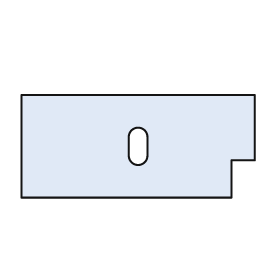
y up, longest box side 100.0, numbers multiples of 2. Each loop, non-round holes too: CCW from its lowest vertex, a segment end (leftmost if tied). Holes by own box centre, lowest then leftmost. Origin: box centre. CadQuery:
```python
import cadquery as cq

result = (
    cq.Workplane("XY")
    .moveTo(-50.0, -22.0)
    .lineTo(40.0, -22.0)
    .lineTo(40.0, -6.0)
    .lineTo(50.0, -6.0)
    .lineTo(50.0, 22.0)
    .lineTo(-50.0, 22.0)
    .close()
    .moveTo(-4.0, -4.0)
    .threePointArc((0.0, -8.0), (4.0, -4.0))
    .lineTo(4.0, 4.0)
    .threePointArc((0.0, 8.0), (-4.0, 4.0))
    .close()
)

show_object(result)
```